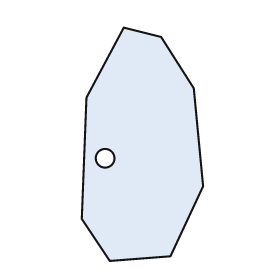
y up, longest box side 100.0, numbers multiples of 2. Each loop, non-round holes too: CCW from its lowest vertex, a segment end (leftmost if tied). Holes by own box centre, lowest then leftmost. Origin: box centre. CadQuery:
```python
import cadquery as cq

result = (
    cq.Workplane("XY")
    .moveTo(-14.0, -50.0)
    .lineTo(12.0, -48.0)
    .lineTo(26.0, -18.0)
    .lineTo(22.0, 24.0)
    .lineTo(8.0, 46.0)
    .lineTo(-8.0, 50.0)
    .lineTo(-24.0, 20.0)
    .lineTo(-26.0, -32.0)
    .close()
    .moveTo(-16.0, -6.0)
    .circle(4.0)
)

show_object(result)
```